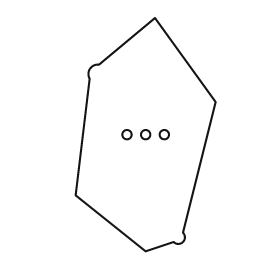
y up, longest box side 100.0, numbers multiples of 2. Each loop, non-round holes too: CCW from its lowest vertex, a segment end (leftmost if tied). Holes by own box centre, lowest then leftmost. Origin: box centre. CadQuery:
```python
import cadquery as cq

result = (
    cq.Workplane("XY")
    .moveTo(0.0, -50.0)
    .lineTo(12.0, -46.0)
    .threePointArc((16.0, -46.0), (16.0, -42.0))
    .lineTo(30.0, 14.0)
    .lineTo(4.0, 50.0)
    .lineTo(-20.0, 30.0)
    .threePointArc((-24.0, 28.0), (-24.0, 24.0))
    .lineTo(-30.0, -26.0)
    .close()
    .moveTo(-8.0, 0.0)
    .circle(2.0)
    .moveTo(0.0, 0.0)
    .circle(2.0)
    .moveTo(8.0, 0.0)
    .circle(2.0)
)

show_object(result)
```